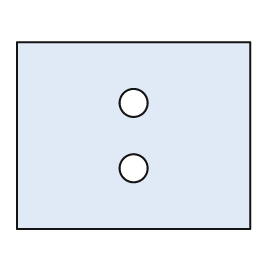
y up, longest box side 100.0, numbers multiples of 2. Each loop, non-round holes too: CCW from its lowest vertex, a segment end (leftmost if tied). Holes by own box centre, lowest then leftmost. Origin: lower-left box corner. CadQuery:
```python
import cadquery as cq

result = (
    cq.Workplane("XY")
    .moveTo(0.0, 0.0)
    .lineTo(100.0, 0.0)
    .lineTo(100.0, 80.0)
    .lineTo(0.0, 80.0)
    .close()
    .moveTo(50.0, 26.0)
    .circle(6.0)
    .moveTo(50.0, 54.0)
    .circle(6.0)
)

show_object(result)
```